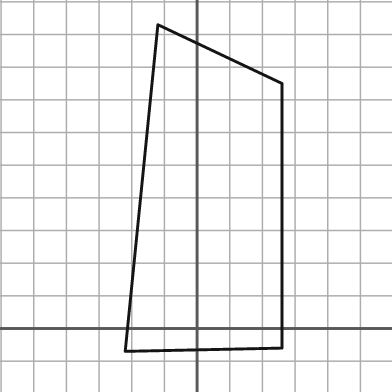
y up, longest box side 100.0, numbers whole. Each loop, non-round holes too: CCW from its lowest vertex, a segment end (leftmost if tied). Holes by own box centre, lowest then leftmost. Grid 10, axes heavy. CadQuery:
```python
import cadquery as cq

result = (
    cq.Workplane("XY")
    .moveTo(-22.0, -7.0)
    .lineTo(26.0, -6.0)
    .lineTo(26.0, 75.0)
    .lineTo(-12.0, 93.0)
    .close()
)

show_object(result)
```